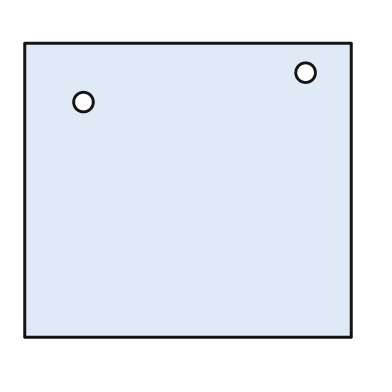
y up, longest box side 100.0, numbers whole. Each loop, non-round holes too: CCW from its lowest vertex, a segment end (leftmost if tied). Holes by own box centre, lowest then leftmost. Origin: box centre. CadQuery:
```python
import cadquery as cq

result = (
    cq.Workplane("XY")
    .moveTo(-50.0, -45.0)
    .lineTo(50.0, -45.0)
    .lineTo(50.0, 45.0)
    .lineTo(-50.0, 45.0)
    .close()
    .moveTo(-32.0, 27.0)
    .circle(3.0)
    .moveTo(36.0, 36.0)
    .circle(3.0)
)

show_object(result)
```